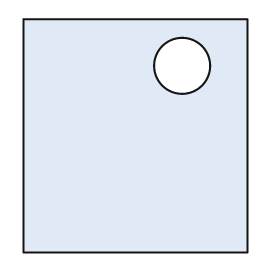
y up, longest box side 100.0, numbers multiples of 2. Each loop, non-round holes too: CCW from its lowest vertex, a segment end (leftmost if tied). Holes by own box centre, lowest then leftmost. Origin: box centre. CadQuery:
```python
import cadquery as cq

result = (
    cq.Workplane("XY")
    .moveTo(-48.0, -50.0)
    .lineTo(48.0, -50.0)
    .lineTo(48.0, 50.0)
    .lineTo(-48.0, 50.0)
    .close()
    .moveTo(20.0, 30.0)
    .circle(12.0)
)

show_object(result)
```